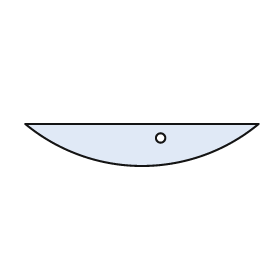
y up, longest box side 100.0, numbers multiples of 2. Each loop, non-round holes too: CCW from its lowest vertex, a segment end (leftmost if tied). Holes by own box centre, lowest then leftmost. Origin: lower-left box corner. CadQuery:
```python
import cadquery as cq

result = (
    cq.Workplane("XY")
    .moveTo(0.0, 18.0)
    .threePointArc((50.0, 0.0), (100.0, 18.0))
    .close()
    .moveTo(58.0, 12.0)
    .circle(2.0)
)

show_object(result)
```